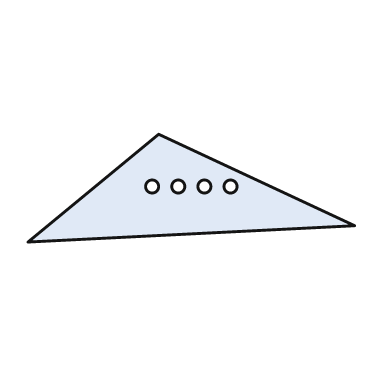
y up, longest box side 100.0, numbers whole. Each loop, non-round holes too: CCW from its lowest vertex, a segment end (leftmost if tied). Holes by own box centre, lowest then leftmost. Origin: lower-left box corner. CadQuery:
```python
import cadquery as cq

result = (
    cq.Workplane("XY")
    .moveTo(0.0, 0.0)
    .lineTo(100.0, 5.0)
    .lineTo(40.0, 33.0)
    .close()
    .moveTo(38.0, 17.0)
    .circle(2.0)
    .moveTo(46.0, 17.0)
    .circle(2.0)
    .moveTo(54.0, 17.0)
    .circle(2.0)
    .moveTo(62.0, 17.0)
    .circle(2.0)
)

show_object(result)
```